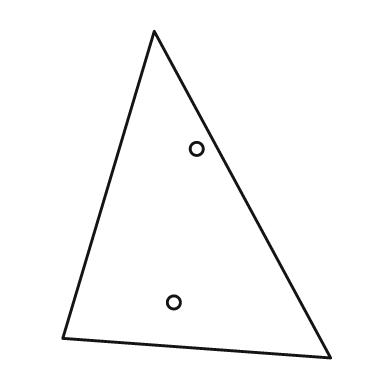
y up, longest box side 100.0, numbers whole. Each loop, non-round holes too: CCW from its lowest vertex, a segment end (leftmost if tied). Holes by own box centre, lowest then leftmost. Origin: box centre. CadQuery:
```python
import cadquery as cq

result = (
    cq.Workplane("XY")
    .moveTo(41.0, -50.0)
    .lineTo(-13.0, 50.0)
    .lineTo(-41.0, -44.0)
    .close()
    .moveTo(-7.0, -33.0)
    .circle(2.0)
    .moveTo(0.0, 14.0)
    .circle(2.0)
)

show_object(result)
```